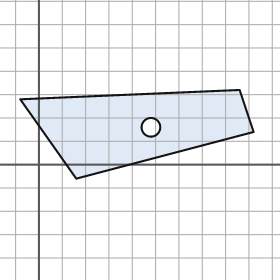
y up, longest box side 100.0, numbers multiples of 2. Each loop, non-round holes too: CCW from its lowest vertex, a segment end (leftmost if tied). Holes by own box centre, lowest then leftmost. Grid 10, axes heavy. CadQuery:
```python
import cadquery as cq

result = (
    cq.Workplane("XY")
    .moveTo(16.0, -6.0)
    .lineTo(92.0, 14.0)
    .lineTo(86.0, 32.0)
    .lineTo(-8.0, 28.0)
    .close()
    .moveTo(48.0, 16.0)
    .circle(4.0)
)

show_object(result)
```